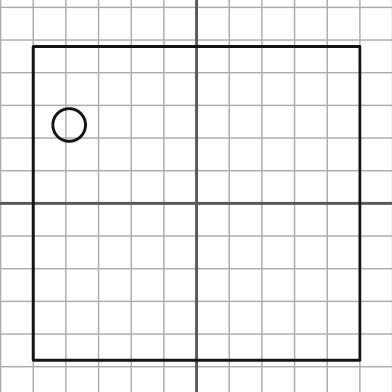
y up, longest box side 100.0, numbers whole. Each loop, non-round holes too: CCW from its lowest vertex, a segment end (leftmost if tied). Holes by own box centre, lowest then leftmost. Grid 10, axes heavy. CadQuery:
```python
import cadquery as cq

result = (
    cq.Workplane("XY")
    .moveTo(-50.0, -48.0)
    .lineTo(50.0, -48.0)
    .lineTo(50.0, 48.0)
    .lineTo(-50.0, 48.0)
    .close()
    .moveTo(-39.0, 24.0)
    .circle(5.0)
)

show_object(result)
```